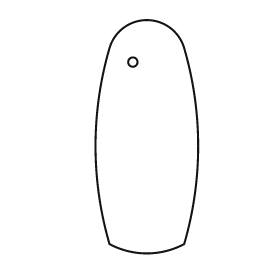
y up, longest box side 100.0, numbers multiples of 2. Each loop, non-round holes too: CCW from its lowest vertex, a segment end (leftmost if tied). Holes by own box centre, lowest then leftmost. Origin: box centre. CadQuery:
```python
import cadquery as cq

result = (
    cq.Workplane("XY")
    .moveTo(-16.0, -46.0)
    .threePointArc((0.0, -50.0), (16.0, -46.0))
    .threePointArc((22.0, -4.0), (16.0, 38.0))
    .threePointArc((0.0, 50.0), (-16.0, 38.0))
    .threePointArc((-22.0, -4.0), (-16.0, -46.0))
    .close()
    .moveTo(-6.0, 32.0)
    .circle(2.0)
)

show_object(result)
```